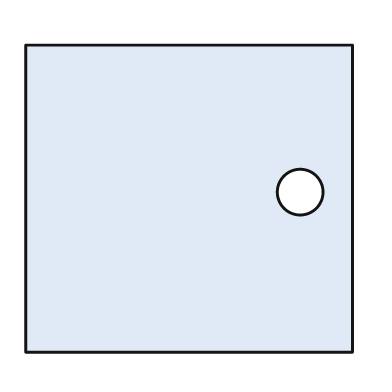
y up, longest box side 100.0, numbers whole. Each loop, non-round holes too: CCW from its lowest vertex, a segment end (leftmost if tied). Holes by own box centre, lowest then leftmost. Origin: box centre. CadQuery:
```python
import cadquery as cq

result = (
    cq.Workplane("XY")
    .moveTo(-50.0, -47.0)
    .lineTo(50.0, -47.0)
    .lineTo(50.0, 47.0)
    .lineTo(-50.0, 47.0)
    .close()
    .moveTo(34.0, 2.0)
    .circle(7.0)
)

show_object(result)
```